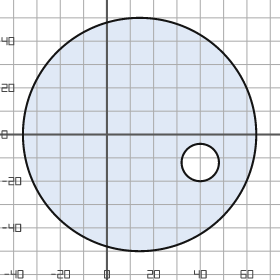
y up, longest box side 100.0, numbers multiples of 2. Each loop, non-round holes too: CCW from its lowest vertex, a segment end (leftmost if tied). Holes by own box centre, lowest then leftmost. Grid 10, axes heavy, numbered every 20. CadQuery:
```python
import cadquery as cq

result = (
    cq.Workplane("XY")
    .moveTo(14.0, 0.0)
    .circle(50.0)
    .moveTo(40.0, -12.0)
    .circle(8.0)
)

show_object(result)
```